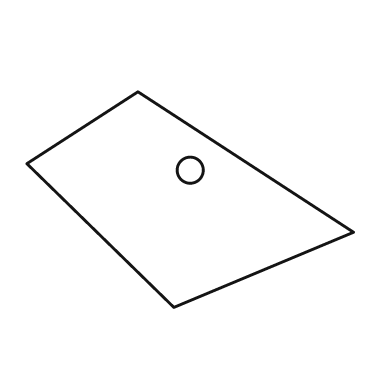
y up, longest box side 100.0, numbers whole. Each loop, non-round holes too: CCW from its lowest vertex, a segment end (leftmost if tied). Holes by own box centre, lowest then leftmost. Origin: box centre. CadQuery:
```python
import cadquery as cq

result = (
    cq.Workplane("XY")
    .moveTo(-5.0, -33.0)
    .lineTo(50.0, -10.0)
    .lineTo(-16.0, 33.0)
    .lineTo(-50.0, 11.0)
    .close()
    .moveTo(0.0, 9.0)
    .circle(4.0)
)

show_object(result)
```